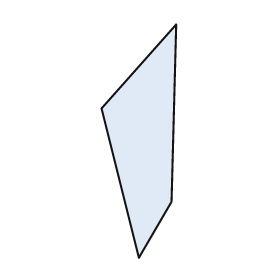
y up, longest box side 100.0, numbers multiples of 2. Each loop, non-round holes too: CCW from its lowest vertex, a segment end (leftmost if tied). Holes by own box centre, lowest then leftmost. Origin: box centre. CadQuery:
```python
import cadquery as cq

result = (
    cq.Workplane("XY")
    .moveTo(0.0, -50.0)
    .lineTo(14.0, -26.0)
    .lineTo(16.0, 50.0)
    .lineTo(-16.0, 14.0)
    .close()
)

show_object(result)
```